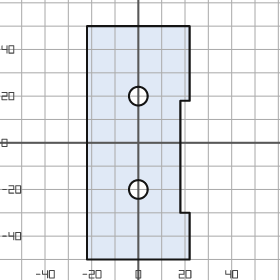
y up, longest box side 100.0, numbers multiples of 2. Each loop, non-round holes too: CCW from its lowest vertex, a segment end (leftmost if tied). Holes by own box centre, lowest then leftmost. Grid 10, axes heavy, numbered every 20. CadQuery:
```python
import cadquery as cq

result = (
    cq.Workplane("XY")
    .moveTo(-22.0, -50.0)
    .lineTo(22.0, -50.0)
    .lineTo(22.0, -30.0)
    .lineTo(18.0, -30.0)
    .lineTo(18.0, 18.0)
    .lineTo(22.0, 18.0)
    .lineTo(22.0, 50.0)
    .lineTo(-22.0, 50.0)
    .close()
    .moveTo(0.0, -20.0)
    .circle(4.0)
    .moveTo(0.0, 20.0)
    .circle(4.0)
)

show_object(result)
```